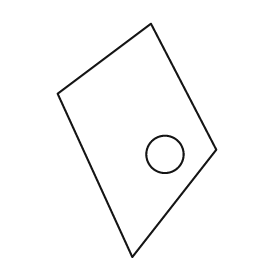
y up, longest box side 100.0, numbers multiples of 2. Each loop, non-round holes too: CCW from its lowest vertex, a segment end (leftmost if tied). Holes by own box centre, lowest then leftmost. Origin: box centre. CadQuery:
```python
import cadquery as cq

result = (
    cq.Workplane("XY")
    .moveTo(-2.0, -50.0)
    .lineTo(34.0, -4.0)
    .lineTo(6.0, 50.0)
    .lineTo(-34.0, 20.0)
    .close()
    .moveTo(12.0, -6.0)
    .circle(8.0)
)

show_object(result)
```